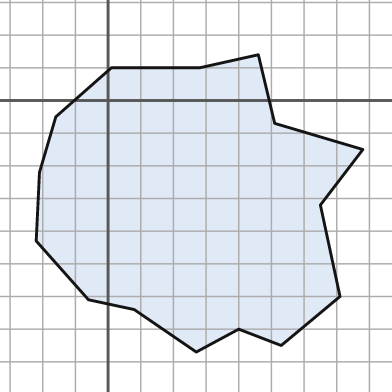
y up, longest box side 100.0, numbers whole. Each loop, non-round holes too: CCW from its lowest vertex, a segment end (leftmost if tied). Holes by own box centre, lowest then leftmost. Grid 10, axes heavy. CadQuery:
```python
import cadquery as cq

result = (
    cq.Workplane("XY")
    .moveTo(27.0, -77.0)
    .lineTo(40.0, -70.0)
    .lineTo(53.0, -75.0)
    .lineTo(71.0, -60.0)
    .lineTo(65.0, -32.0)
    .lineTo(78.0, -15.0)
    .lineTo(51.0, -7.0)
    .lineTo(46.0, 14.0)
    .lineTo(28.0, 10.0)
    .lineTo(1.0, 10.0)
    .lineTo(-16.0, -5.0)
    .lineTo(-21.0, -22.0)
    .lineTo(-22.0, -43.0)
    .lineTo(-6.0, -61.0)
    .lineTo(8.0, -64.0)
    .close()
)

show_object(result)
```